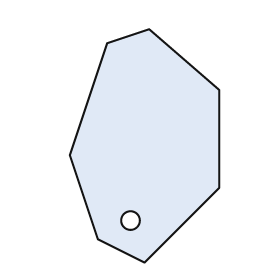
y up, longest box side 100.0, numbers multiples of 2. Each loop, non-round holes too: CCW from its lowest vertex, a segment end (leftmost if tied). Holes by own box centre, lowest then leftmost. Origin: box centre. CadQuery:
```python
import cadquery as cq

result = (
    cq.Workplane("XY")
    .moveTo(0.0, -50.0)
    .lineTo(32.0, -18.0)
    .lineTo(32.0, 24.0)
    .lineTo(2.0, 50.0)
    .lineTo(-16.0, 44.0)
    .lineTo(-32.0, -4.0)
    .lineTo(-20.0, -40.0)
    .close()
    .moveTo(-6.0, -32.0)
    .circle(4.0)
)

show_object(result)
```